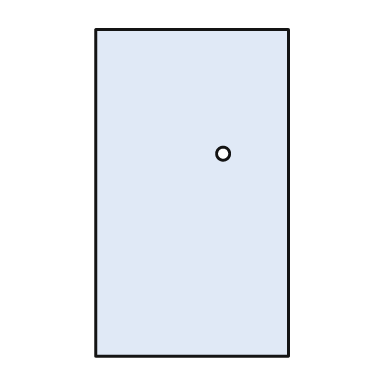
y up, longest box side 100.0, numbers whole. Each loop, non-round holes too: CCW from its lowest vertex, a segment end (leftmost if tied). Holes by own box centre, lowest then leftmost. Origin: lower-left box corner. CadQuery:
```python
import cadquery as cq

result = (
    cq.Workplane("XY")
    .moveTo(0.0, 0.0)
    .lineTo(59.0, 0.0)
    .lineTo(59.0, 100.0)
    .lineTo(0.0, 100.0)
    .close()
    .moveTo(39.0, 62.0)
    .circle(2.0)
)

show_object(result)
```